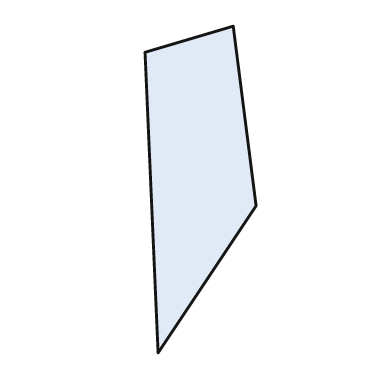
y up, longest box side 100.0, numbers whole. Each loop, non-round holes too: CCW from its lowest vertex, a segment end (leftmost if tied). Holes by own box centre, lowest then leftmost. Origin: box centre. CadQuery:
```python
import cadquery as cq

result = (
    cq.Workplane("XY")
    .moveTo(-13.0, -50.0)
    .lineTo(17.0, -5.0)
    .lineTo(10.0, 50.0)
    .lineTo(-17.0, 42.0)
    .close()
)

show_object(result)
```